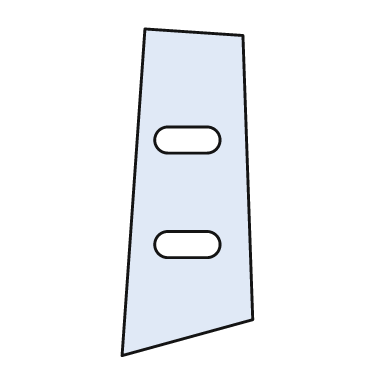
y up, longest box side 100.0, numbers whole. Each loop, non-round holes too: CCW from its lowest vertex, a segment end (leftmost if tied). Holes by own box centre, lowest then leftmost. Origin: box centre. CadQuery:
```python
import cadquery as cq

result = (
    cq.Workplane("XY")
    .moveTo(-20.0, -50.0)
    .lineTo(20.0, -39.0)
    .lineTo(17.0, 48.0)
    .lineTo(-13.0, 50.0)
    .close()
    .moveTo(-6.0, -20.0)
    .lineTo(6.0, -20.0)
    .threePointArc((10.0, -16.0), (6.0, -12.0))
    .lineTo(-6.0, -12.0)
    .threePointArc((-10.0, -16.0), (-6.0, -20.0))
    .close()
    .moveTo(-6.0, 12.0)
    .lineTo(6.0, 12.0)
    .threePointArc((10.0, 16.0), (6.0, 20.0))
    .lineTo(-6.0, 20.0)
    .threePointArc((-10.0, 16.0), (-6.0, 12.0))
    .close()
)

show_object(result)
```